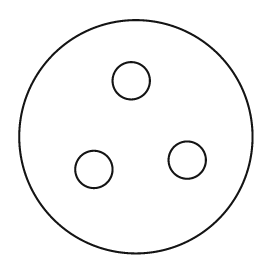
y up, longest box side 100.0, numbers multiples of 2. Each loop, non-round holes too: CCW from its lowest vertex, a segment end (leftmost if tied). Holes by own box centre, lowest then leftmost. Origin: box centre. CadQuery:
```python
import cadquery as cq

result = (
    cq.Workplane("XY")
    .moveTo(0.0, 0.0)
    .circle(50.0)
    .moveTo(-18.0, -14.0)
    .circle(8.0)
    .moveTo(22.0, -10.0)
    .circle(8.0)
    .moveTo(-2.0, 24.0)
    .circle(8.0)
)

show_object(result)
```